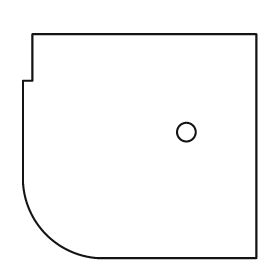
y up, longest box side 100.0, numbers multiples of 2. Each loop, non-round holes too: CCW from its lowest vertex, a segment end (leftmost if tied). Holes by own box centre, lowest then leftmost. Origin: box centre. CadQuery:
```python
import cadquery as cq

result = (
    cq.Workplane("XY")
    .moveTo(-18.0, -48.0)
    .lineTo(50.0, -48.0)
    .lineTo(50.0, 48.0)
    .lineTo(-46.0, 48.0)
    .lineTo(-46.0, 28.0)
    .lineTo(-50.0, 28.0)
    .lineTo(-50.0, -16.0)
    .threePointArc((-40.0, -38.0), (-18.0, -48.0))
    .close()
    .moveTo(20.0, 6.0)
    .circle(4.0)
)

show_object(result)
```